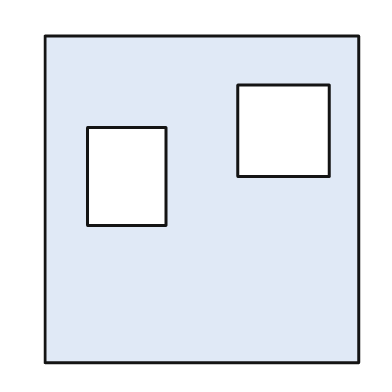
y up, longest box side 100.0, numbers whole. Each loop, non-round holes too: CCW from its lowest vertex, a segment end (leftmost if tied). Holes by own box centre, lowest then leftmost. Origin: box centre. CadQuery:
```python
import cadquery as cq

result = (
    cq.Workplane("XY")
    .moveTo(-48.0, -50.0)
    .lineTo(48.0, -50.0)
    .lineTo(48.0, 50.0)
    .lineTo(-48.0, 50.0)
    .close()
    .moveTo(-35.0, -8.0)
    .lineTo(-11.0, -8.0)
    .lineTo(-11.0, 22.0)
    .lineTo(-35.0, 22.0)
    .close()
    .moveTo(11.0, 7.0)
    .lineTo(39.0, 7.0)
    .lineTo(39.0, 35.0)
    .lineTo(11.0, 35.0)
    .close()
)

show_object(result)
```